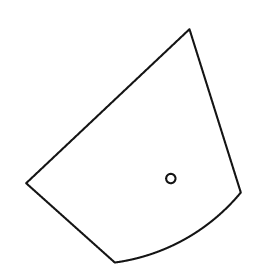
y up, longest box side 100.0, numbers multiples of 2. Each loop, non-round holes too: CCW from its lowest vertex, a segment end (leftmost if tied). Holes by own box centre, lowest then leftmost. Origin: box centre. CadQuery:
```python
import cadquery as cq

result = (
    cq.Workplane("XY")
    .moveTo(-8.0, -50.0)
    .threePointArc((22.0, -40.0), (46.0, -20.0))
    .lineTo(24.0, 50.0)
    .lineTo(-46.0, -16.0)
    .close()
    .moveTo(16.0, -14.0)
    .circle(2.0)
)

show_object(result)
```